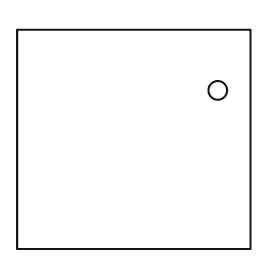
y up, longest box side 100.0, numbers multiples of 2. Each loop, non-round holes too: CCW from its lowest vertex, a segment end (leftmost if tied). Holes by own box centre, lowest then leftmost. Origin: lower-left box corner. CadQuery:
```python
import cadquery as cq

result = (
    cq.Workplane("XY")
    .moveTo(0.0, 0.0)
    .lineTo(100.0, 0.0)
    .lineTo(100.0, 94.0)
    .lineTo(0.0, 94.0)
    .close()
    .moveTo(86.0, 68.0)
    .circle(4.0)
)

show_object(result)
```